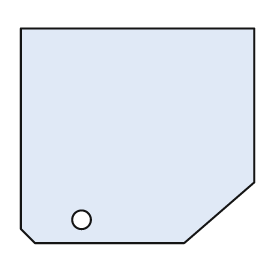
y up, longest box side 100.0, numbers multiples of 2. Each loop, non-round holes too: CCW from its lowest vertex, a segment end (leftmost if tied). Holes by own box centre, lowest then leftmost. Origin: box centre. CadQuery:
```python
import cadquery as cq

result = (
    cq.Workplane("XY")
    .moveTo(-44.0, -46.0)
    .lineTo(20.0, -46.0)
    .lineTo(50.0, -20.0)
    .lineTo(50.0, 46.0)
    .lineTo(-50.0, 46.0)
    .lineTo(-50.0, -40.0)
    .close()
    .moveTo(-24.0, -36.0)
    .circle(4.0)
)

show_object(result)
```